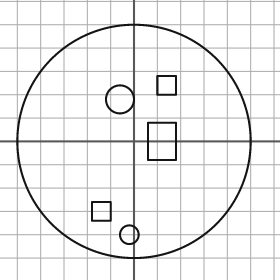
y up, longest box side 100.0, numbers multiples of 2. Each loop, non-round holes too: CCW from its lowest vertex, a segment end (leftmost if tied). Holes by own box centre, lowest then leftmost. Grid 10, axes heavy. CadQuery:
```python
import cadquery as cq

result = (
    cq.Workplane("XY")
    .moveTo(0.0, 0.0)
    .circle(50.0)
    .moveTo(-2.0, -40.0)
    .circle(4.0)
    .moveTo(-18.0, -34.0)
    .lineTo(-10.0, -34.0)
    .lineTo(-10.0, -26.0)
    .lineTo(-18.0, -26.0)
    .close()
    .moveTo(6.0, -8.0)
    .lineTo(18.0, -8.0)
    .lineTo(18.0, 8.0)
    .lineTo(6.0, 8.0)
    .close()
    .moveTo(-6.0, 18.0)
    .circle(6.0)
    .moveTo(10.0, 20.0)
    .lineTo(18.0, 20.0)
    .lineTo(18.0, 28.0)
    .lineTo(10.0, 28.0)
    .close()
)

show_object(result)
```